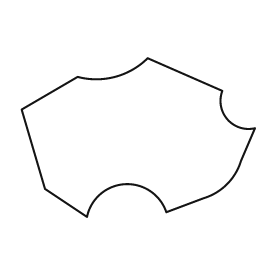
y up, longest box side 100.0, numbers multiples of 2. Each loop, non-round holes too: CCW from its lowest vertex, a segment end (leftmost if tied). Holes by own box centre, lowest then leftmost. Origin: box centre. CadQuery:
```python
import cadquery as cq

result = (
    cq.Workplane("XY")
    .moveTo(-22.0, -34.0)
    .threePointArc((-6.0, -20.0), (12.0, -32.0))
    .lineTo(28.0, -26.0)
    .threePointArc((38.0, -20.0), (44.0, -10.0))
    .lineTo(50.0, 4.0)
    .threePointArc((38.0, 8.0), (36.0, 20.0))
    .lineTo(4.0, 34.0)
    .threePointArc((-10.0, 26.0), (-26.0, 26.0))
    .lineTo(-50.0, 12.0)
    .lineTo(-40.0, -22.0)
    .close()
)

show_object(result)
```